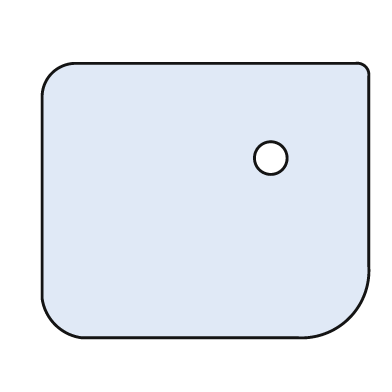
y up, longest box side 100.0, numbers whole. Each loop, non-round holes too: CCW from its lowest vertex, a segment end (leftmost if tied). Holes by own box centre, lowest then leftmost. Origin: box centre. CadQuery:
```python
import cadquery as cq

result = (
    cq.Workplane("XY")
    .moveTo(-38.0, -42.0)
    .lineTo(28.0, -42.0)
    .threePointArc((44.0, -36.0), (50.0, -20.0))
    .lineTo(50.0, 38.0)
    .threePointArc((49.0, 41.0), (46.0, 42.0))
    .lineTo(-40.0, 42.0)
    .threePointArc((-47.0, 39.0), (-50.0, 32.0))
    .lineTo(-50.0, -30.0)
    .threePointArc((-46.0, -38.0), (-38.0, -42.0))
    .close()
    .moveTo(20.0, 13.0)
    .circle(5.0)
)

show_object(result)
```